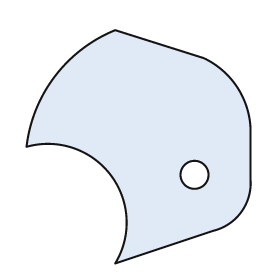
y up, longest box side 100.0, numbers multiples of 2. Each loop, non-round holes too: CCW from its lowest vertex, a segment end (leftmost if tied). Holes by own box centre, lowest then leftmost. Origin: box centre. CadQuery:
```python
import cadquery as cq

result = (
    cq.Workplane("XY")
    .moveTo(-10.0, -50.0)
    .lineTo(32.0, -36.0)
    .threePointArc((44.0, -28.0), (48.0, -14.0))
    .lineTo(48.0, 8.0)
    .threePointArc((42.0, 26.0), (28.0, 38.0))
    .lineTo(-10.0, 50.0)
    .threePointArc((-36.0, 30.0), (-48.0, 0.0))
    .threePointArc((-12.0, -12.0), (-10.0, -50.0))
    .close()
    .moveTo(24.0, -12.0)
    .circle(6.0)
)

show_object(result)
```